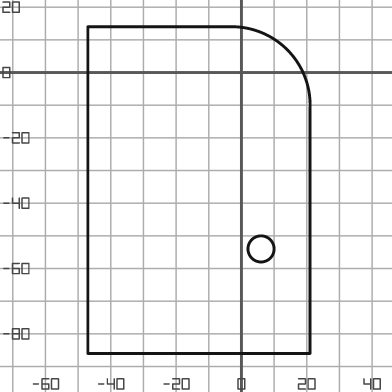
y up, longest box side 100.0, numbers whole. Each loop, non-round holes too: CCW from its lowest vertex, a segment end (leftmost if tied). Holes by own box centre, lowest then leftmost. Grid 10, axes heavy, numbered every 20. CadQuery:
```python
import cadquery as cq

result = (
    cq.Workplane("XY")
    .moveTo(-47.0, -86.0)
    .lineTo(21.0, -86.0)
    .lineTo(21.0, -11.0)
    .threePointArc((14.0, 7.0), (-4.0, 14.0))
    .lineTo(-47.0, 14.0)
    .close()
    .moveTo(6.0, -54.0)
    .circle(4.0)
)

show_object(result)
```